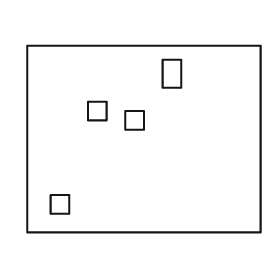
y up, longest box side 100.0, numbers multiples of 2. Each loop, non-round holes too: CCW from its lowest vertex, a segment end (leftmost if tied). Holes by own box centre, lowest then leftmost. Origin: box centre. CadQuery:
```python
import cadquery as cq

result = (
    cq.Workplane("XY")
    .moveTo(-50.0, -40.0)
    .lineTo(50.0, -40.0)
    .lineTo(50.0, 40.0)
    .lineTo(-50.0, 40.0)
    .close()
    .moveTo(-40.0, -32.0)
    .lineTo(-32.0, -32.0)
    .lineTo(-32.0, -24.0)
    .lineTo(-40.0, -24.0)
    .close()
    .moveTo(-8.0, 4.0)
    .lineTo(0.0, 4.0)
    .lineTo(0.0, 12.0)
    .lineTo(-8.0, 12.0)
    .close()
    .moveTo(-24.0, 8.0)
    .lineTo(-16.0, 8.0)
    .lineTo(-16.0, 16.0)
    .lineTo(-24.0, 16.0)
    .close()
    .moveTo(8.0, 22.0)
    .lineTo(16.0, 22.0)
    .lineTo(16.0, 34.0)
    .lineTo(8.0, 34.0)
    .close()
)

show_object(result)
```